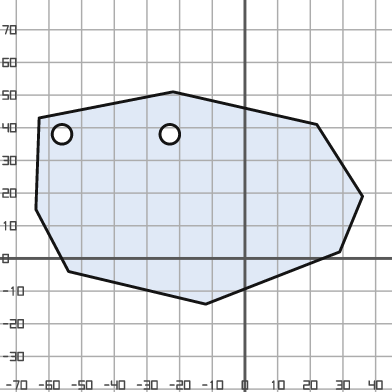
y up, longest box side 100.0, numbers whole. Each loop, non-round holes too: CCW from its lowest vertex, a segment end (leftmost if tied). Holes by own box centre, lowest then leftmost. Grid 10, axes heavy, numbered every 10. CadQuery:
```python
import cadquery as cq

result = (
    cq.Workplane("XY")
    .moveTo(-12.0, -14.0)
    .lineTo(29.0, 2.0)
    .lineTo(36.0, 19.0)
    .lineTo(22.0, 41.0)
    .lineTo(-22.0, 51.0)
    .lineTo(-63.0, 43.0)
    .lineTo(-64.0, 15.0)
    .lineTo(-54.0, -4.0)
    .close()
    .moveTo(-56.0, 38.0)
    .circle(3.0)
    .moveTo(-23.0, 38.0)
    .circle(3.0)
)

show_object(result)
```